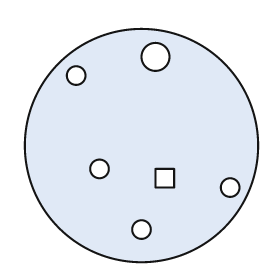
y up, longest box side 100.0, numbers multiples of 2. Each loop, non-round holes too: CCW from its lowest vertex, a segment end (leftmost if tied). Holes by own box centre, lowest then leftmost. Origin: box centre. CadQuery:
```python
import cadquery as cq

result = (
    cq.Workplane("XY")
    .moveTo(0.0, 0.0)
    .circle(50.0)
    .moveTo(0.0, -36.0)
    .circle(4.0)
    .moveTo(38.0, -18.0)
    .circle(4.0)
    .moveTo(6.0, -18.0)
    .lineTo(14.0, -18.0)
    .lineTo(14.0, -10.0)
    .lineTo(6.0, -10.0)
    .close()
    .moveTo(-18.0, -10.0)
    .circle(4.0)
    .moveTo(-28.0, 30.0)
    .circle(4.0)
    .moveTo(6.0, 38.0)
    .circle(6.0)
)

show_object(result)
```